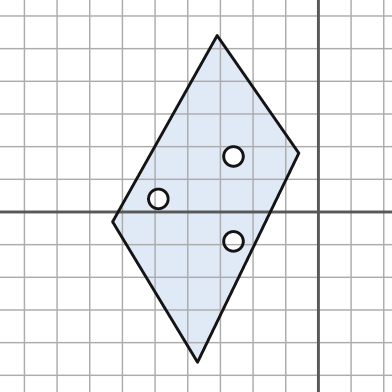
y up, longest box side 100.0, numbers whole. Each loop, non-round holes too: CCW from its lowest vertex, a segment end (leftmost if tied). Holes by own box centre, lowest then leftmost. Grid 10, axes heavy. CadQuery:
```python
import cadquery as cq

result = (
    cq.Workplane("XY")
    .moveTo(-37.0, -46.0)
    .lineTo(-6.0, 18.0)
    .lineTo(-31.0, 54.0)
    .lineTo(-63.0, -3.0)
    .close()
    .moveTo(-26.0, -9.0)
    .circle(3.0)
    .moveTo(-49.0, 4.0)
    .circle(3.0)
    .moveTo(-26.0, 17.0)
    .circle(3.0)
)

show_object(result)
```